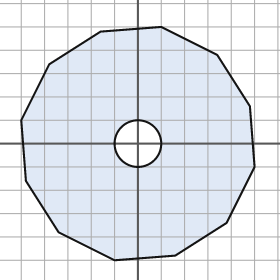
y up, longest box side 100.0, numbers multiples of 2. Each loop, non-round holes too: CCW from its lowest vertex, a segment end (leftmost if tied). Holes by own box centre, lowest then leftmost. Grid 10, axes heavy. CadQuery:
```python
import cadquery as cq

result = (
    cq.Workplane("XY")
    .moveTo(-10.0, -50.0)
    .lineTo(16.0, -48.0)
    .lineTo(38.0, -34.0)
    .lineTo(50.0, -10.0)
    .lineTo(48.0, 16.0)
    .lineTo(34.0, 38.0)
    .lineTo(10.0, 50.0)
    .lineTo(-16.0, 48.0)
    .lineTo(-38.0, 34.0)
    .lineTo(-50.0, 10.0)
    .lineTo(-48.0, -16.0)
    .lineTo(-34.0, -38.0)
    .close()
    .moveTo(0.0, 0.0)
    .circle(10.0)
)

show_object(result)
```